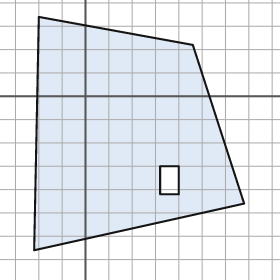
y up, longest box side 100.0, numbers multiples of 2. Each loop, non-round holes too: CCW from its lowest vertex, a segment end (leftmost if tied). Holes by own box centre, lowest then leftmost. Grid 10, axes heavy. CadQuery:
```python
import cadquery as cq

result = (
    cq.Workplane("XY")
    .moveTo(-22.0, -66.0)
    .lineTo(68.0, -46.0)
    .lineTo(46.0, 22.0)
    .lineTo(-20.0, 34.0)
    .close()
    .moveTo(32.0, -42.0)
    .lineTo(40.0, -42.0)
    .lineTo(40.0, -30.0)
    .lineTo(32.0, -30.0)
    .close()
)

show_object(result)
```